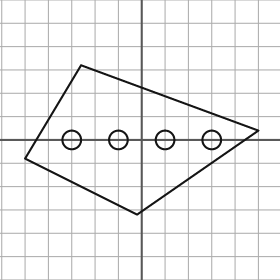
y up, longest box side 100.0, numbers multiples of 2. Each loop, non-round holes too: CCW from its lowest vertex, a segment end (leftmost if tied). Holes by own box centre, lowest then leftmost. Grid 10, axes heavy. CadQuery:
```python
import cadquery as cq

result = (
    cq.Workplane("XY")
    .moveTo(-2.0, -32.0)
    .lineTo(50.0, 4.0)
    .lineTo(-26.0, 32.0)
    .lineTo(-50.0, -8.0)
    .close()
    .moveTo(-30.0, 0.0)
    .circle(4.0)
    .moveTo(-10.0, 0.0)
    .circle(4.0)
    .moveTo(10.0, 0.0)
    .circle(4.0)
    .moveTo(30.0, 0.0)
    .circle(4.0)
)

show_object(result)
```